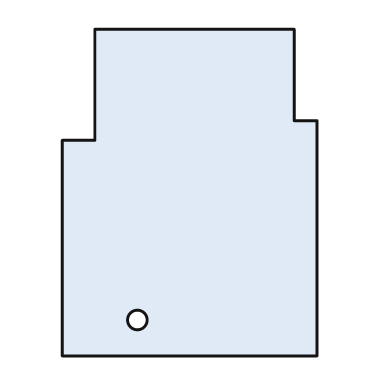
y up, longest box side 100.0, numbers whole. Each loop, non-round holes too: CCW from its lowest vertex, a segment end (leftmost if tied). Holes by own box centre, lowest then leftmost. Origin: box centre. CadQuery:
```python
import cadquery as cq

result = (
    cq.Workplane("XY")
    .moveTo(-39.0, -50.0)
    .lineTo(39.0, -50.0)
    .lineTo(39.0, 22.0)
    .lineTo(32.0, 22.0)
    .lineTo(32.0, 50.0)
    .lineTo(-29.0, 50.0)
    .lineTo(-29.0, 16.0)
    .lineTo(-39.0, 16.0)
    .close()
    .moveTo(-16.0, -39.0)
    .circle(3.0)
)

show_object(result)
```